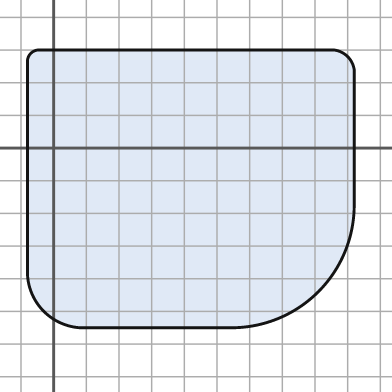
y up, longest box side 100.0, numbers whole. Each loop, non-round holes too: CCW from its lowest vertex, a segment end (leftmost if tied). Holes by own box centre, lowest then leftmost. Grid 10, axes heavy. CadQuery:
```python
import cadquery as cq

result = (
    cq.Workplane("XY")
    .moveTo(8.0, -55.0)
    .lineTo(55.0, -55.0)
    .threePointArc((81.0, -44.0), (92.0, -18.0))
    .lineTo(92.0, 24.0)
    .threePointArc((90.0, 28.0), (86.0, 30.0))
    .lineTo(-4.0, 30.0)
    .threePointArc((-7.0, 29.0), (-8.0, 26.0))
    .lineTo(-8.0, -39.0)
    .threePointArc((-3.0, -50.0), (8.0, -55.0))
    .close()
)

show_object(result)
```